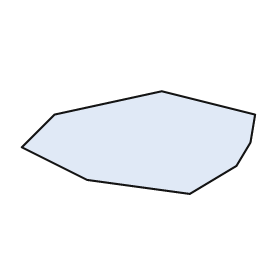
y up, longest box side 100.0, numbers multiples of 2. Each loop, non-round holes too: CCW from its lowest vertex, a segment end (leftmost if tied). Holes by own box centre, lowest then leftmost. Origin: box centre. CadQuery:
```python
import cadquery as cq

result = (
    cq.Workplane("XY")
    .moveTo(22.0, -22.0)
    .lineTo(42.0, -10.0)
    .lineTo(48.0, 0.0)
    .lineTo(50.0, 12.0)
    .lineTo(10.0, 22.0)
    .lineTo(-36.0, 12.0)
    .lineTo(-50.0, -2.0)
    .lineTo(-22.0, -16.0)
    .close()
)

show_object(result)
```